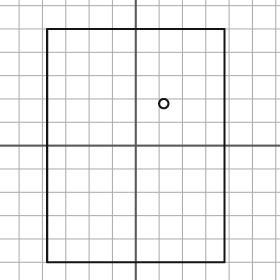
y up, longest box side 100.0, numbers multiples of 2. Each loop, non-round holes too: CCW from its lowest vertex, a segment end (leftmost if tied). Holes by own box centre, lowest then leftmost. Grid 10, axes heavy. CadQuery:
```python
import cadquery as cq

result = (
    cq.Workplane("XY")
    .moveTo(-38.0, -50.0)
    .lineTo(38.0, -50.0)
    .lineTo(38.0, 50.0)
    .lineTo(-38.0, 50.0)
    .close()
    .moveTo(12.0, 18.0)
    .circle(2.0)
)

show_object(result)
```